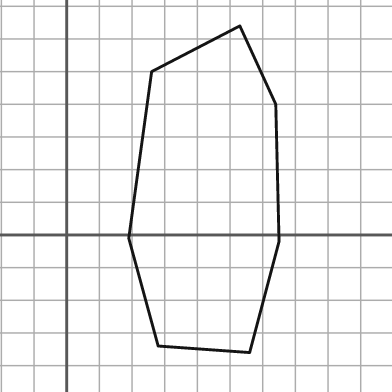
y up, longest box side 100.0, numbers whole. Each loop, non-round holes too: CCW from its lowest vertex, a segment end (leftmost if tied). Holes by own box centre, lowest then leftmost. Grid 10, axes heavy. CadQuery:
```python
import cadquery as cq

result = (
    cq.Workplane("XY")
    .moveTo(56.0, -36.0)
    .lineTo(65.0, -2.0)
    .lineTo(64.0, 40.0)
    .lineTo(53.0, 64.0)
    .lineTo(26.0, 50.0)
    .lineTo(19.0, -1.0)
    .lineTo(28.0, -34.0)
    .close()
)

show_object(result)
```